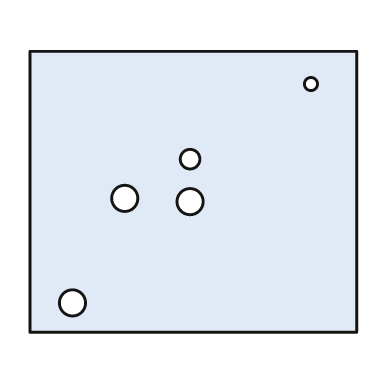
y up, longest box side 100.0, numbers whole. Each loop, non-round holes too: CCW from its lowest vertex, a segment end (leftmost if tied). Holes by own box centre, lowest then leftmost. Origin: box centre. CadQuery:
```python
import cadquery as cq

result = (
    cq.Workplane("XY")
    .moveTo(-50.0, -43.0)
    .lineTo(50.0, -43.0)
    .lineTo(50.0, 43.0)
    .lineTo(-50.0, 43.0)
    .close()
    .moveTo(-37.0, -34.0)
    .circle(4.0)
    .moveTo(-1.0, -3.0)
    .circle(4.0)
    .moveTo(-21.0, -2.0)
    .circle(4.0)
    .moveTo(-1.0, 10.0)
    .circle(3.0)
    .moveTo(36.0, 33.0)
    .circle(2.0)
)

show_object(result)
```